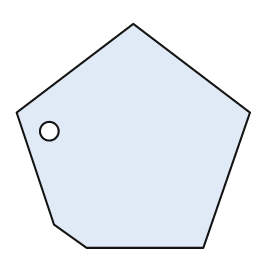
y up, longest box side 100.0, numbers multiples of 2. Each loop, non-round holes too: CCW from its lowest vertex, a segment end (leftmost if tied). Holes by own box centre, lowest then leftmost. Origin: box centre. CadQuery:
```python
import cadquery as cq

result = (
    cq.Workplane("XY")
    .moveTo(-20.0, -48.0)
    .lineTo(30.0, -48.0)
    .lineTo(50.0, 10.0)
    .lineTo(0.0, 48.0)
    .lineTo(-50.0, 10.0)
    .lineTo(-34.0, -38.0)
    .close()
    .moveTo(-36.0, 2.0)
    .circle(4.0)
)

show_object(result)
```